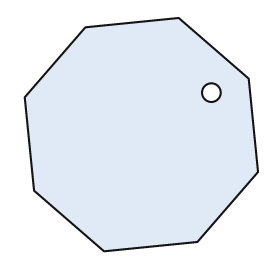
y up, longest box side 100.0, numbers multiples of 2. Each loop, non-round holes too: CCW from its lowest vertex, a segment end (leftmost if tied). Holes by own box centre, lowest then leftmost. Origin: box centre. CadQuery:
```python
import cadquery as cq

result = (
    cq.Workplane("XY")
    .moveTo(-16.0, -50.0)
    .lineTo(24.0, -46.0)
    .lineTo(50.0, -16.0)
    .lineTo(46.0, 24.0)
    .lineTo(16.0, 50.0)
    .lineTo(-24.0, 46.0)
    .lineTo(-50.0, 16.0)
    .lineTo(-46.0, -24.0)
    .close()
    .moveTo(30.0, 18.0)
    .circle(4.0)
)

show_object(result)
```